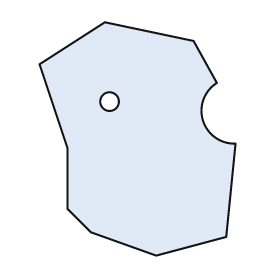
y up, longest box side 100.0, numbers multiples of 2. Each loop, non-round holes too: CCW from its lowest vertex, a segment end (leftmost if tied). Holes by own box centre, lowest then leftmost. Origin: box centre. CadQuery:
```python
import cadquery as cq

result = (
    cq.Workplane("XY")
    .moveTo(8.0, -50.0)
    .lineTo(38.0, -42.0)
    .lineTo(42.0, -2.0)
    .threePointArc((28.0, 8.0), (34.0, 24.0))
    .lineTo(24.0, 42.0)
    .lineTo(-14.0, 50.0)
    .lineTo(-42.0, 32.0)
    .lineTo(-30.0, -4.0)
    .lineTo(-30.0, -30.0)
    .lineTo(-20.0, -40.0)
    .close()
    .moveTo(-12.0, 16.0)
    .circle(4.0)
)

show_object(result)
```